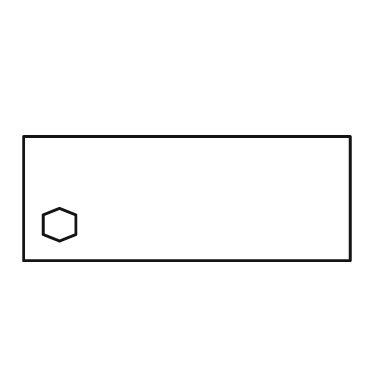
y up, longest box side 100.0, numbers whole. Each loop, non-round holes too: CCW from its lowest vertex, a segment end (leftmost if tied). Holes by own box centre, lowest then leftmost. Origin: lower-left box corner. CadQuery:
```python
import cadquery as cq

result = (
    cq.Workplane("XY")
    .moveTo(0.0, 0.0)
    .lineTo(100.0, 0.0)
    .lineTo(100.0, 38.0)
    .lineTo(0.0, 38.0)
    .close()
    .moveTo(11.0, 6.0)
    .lineTo(16.0, 8.0)
    .lineTo(16.0, 14.0)
    .lineTo(11.0, 16.0)
    .lineTo(6.0, 14.0)
    .lineTo(6.0, 8.0)
    .close()
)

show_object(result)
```